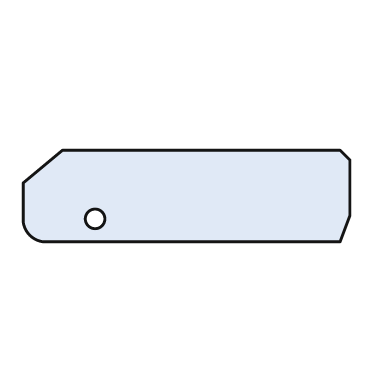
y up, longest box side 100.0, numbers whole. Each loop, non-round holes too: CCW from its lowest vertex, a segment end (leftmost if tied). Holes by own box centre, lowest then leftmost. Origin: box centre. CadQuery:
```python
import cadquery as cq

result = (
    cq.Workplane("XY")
    .moveTo(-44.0, -14.0)
    .lineTo(47.0, -14.0)
    .lineTo(50.0, -6.0)
    .lineTo(50.0, 11.0)
    .lineTo(47.0, 14.0)
    .lineTo(-38.0, 14.0)
    .lineTo(-50.0, 4.0)
    .lineTo(-50.0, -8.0)
    .threePointArc((-48.0, -12.0), (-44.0, -14.0))
    .close()
    .moveTo(-28.0, -7.0)
    .circle(3.0)
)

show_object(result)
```